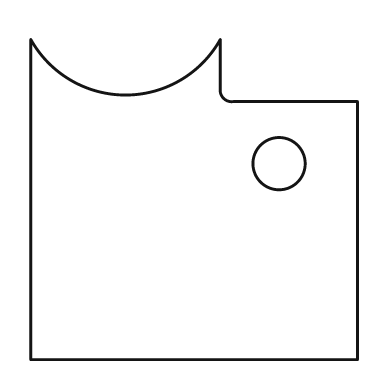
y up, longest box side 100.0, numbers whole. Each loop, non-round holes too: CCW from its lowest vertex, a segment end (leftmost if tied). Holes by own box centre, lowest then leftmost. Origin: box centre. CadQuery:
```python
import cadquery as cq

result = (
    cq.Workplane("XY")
    .moveTo(-50.0, -49.0)
    .lineTo(50.0, -49.0)
    .lineTo(50.0, 30.0)
    .lineTo(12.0, 30.0)
    .threePointArc((9.0, 31.0), (8.0, 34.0))
    .lineTo(8.0, 49.0)
    .threePointArc((-21.0, 32.0), (-50.0, 49.0))
    .close()
    .moveTo(26.0, 11.0)
    .circle(8.0)
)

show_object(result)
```